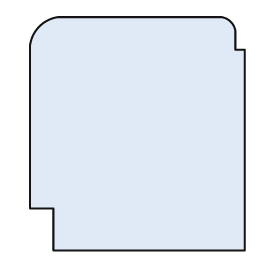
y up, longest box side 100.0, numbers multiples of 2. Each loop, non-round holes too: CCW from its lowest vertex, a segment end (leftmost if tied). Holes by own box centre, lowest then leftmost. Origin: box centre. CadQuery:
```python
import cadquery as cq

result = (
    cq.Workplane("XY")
    .moveTo(-36.0, -50.0)
    .lineTo(46.0, -50.0)
    .lineTo(46.0, 36.0)
    .lineTo(42.0, 36.0)
    .lineTo(42.0, 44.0)
    .threePointArc((40.0, 48.0), (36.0, 50.0))
    .lineTo(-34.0, 50.0)
    .threePointArc((-42.0, 46.0), (-46.0, 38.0))
    .lineTo(-46.0, -32.0)
    .lineTo(-36.0, -32.0)
    .close()
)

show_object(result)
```